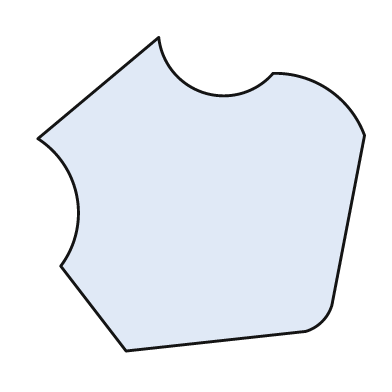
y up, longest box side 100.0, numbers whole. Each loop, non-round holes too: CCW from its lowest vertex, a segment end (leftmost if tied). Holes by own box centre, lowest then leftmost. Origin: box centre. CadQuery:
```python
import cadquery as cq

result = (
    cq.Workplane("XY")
    .moveTo(-23.0, -48.0)
    .lineTo(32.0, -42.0)
    .threePointArc((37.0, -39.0), (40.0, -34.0))
    .lineTo(50.0, 18.0)
    .threePointArc((39.0, 32.0), (22.0, 37.0))
    .threePointArc((1.0, 31.0), (-13.0, 48.0))
    .lineTo(-50.0, 17.0)
    .threePointArc((-38.0, -1.0), (-43.0, -22.0))
    .close()
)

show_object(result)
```